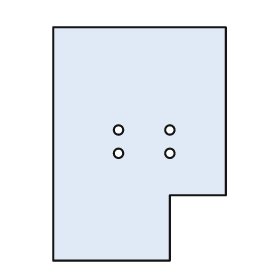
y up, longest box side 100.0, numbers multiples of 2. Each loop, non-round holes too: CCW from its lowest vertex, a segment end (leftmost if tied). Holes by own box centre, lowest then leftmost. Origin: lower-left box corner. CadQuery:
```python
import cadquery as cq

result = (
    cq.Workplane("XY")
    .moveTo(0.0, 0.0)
    .lineTo(50.0, 0.0)
    .lineTo(50.0, 28.0)
    .lineTo(74.0, 28.0)
    .lineTo(74.0, 100.0)
    .lineTo(0.0, 100.0)
    .close()
    .moveTo(28.0, 46.0)
    .circle(2.0)
    .moveTo(50.0, 46.0)
    .circle(2.0)
    .moveTo(28.0, 56.0)
    .circle(2.0)
    .moveTo(50.0, 56.0)
    .circle(2.0)
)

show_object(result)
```